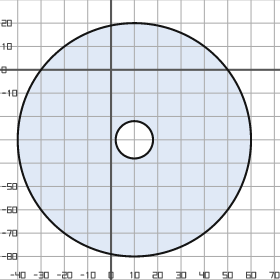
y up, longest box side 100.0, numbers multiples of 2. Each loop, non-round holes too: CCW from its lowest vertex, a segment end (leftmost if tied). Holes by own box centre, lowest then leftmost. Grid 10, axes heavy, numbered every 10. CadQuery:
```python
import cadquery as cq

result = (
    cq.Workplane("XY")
    .moveTo(10.0, -30.0)
    .circle(50.0)
    .moveTo(10.0, -30.0)
    .circle(8.0)
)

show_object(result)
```